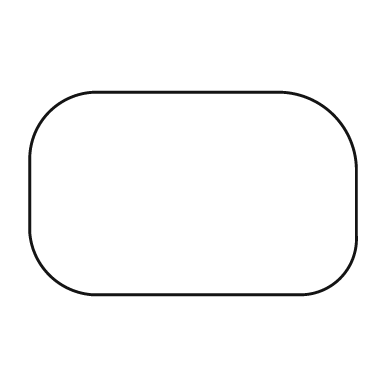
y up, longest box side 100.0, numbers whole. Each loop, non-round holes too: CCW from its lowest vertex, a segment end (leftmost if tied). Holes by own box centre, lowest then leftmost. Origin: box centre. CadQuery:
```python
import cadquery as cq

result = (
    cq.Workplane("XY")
    .moveTo(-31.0, -31.0)
    .lineTo(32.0, -31.0)
    .threePointArc((45.0, -26.0), (50.0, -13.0))
    .lineTo(50.0, 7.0)
    .threePointArc((43.0, 24.0), (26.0, 31.0))
    .lineTo(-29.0, 31.0)
    .threePointArc((-44.0, 25.0), (-50.0, 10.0))
    .lineTo(-50.0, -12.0)
    .threePointArc((-44.0, -25.0), (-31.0, -31.0))
    .close()
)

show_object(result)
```